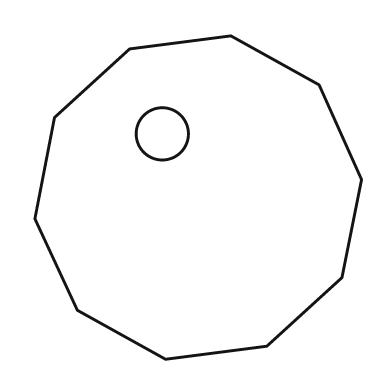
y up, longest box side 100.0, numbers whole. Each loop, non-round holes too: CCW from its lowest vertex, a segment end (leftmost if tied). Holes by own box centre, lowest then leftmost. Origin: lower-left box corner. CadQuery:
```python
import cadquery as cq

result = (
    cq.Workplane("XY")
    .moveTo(40.0, 0.0)
    .lineTo(71.0, 4.0)
    .lineTo(94.0, 25.0)
    .lineTo(100.0, 55.0)
    .lineTo(87.0, 84.0)
    .lineTo(60.0, 99.0)
    .lineTo(29.0, 95.0)
    .lineTo(6.0, 74.0)
    .lineTo(0.0, 43.0)
    .lineTo(13.0, 15.0)
    .close()
    .moveTo(39.0, 69.0)
    .circle(8.0)
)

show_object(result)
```